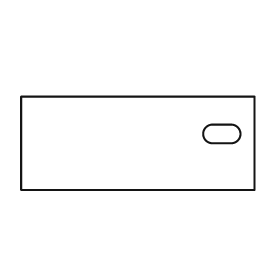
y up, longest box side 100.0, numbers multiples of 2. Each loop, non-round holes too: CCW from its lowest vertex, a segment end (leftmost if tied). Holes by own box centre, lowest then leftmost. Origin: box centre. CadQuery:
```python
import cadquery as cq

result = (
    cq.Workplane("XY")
    .moveTo(-50.0, -20.0)
    .lineTo(50.0, -20.0)
    .lineTo(50.0, 20.0)
    .lineTo(-50.0, 20.0)
    .close()
    .moveTo(32.0, 0.0)
    .lineTo(40.0, 0.0)
    .threePointArc((44.0, 4.0), (40.0, 8.0))
    .lineTo(32.0, 8.0)
    .threePointArc((28.0, 4.0), (32.0, 0.0))
    .close()
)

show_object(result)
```